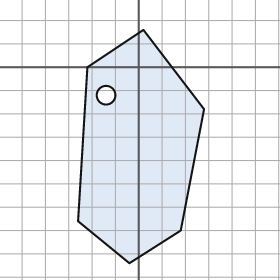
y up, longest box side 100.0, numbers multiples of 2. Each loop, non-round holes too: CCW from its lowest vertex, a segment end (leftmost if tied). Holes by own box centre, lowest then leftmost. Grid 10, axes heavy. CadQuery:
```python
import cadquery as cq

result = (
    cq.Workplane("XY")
    .moveTo(-4.0, -84.0)
    .lineTo(18.0, -70.0)
    .lineTo(28.0, -18.0)
    .lineTo(2.0, 16.0)
    .lineTo(-22.0, 0.0)
    .lineTo(-26.0, -66.0)
    .close()
    .moveTo(-14.0, -12.0)
    .circle(4.0)
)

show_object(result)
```